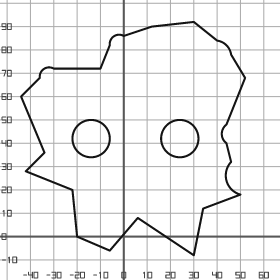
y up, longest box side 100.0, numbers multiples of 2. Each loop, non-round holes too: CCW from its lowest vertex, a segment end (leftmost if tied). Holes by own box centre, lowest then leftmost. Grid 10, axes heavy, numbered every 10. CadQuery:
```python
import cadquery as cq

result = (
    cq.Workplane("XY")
    .moveTo(30.0, -8.0)
    .lineTo(34.0, 12.0)
    .lineTo(50.0, 18.0)
    .threePointArc((44.0, 24.0), (46.0, 32.0))
    .lineTo(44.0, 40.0)
    .threePointArc((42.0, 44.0), (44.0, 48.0))
    .lineTo(52.0, 68.0)
    .lineTo(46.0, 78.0)
    .threePointArc((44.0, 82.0), (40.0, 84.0))
    .lineTo(30.0, 92.0)
    .lineTo(12.0, 90.0)
    .lineTo(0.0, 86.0)
    .threePointArc((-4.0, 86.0), (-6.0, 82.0))
    .lineTo(-10.0, 72.0)
    .lineTo(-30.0, 72.0)
    .threePointArc((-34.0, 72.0), (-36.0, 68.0))
    .lineTo(-44.0, 60.0)
    .lineTo(-34.0, 36.0)
    .lineTo(-42.0, 28.0)
    .lineTo(-22.0, 20.0)
    .lineTo(-20.0, 0.0)
    .lineTo(-6.0, -6.0)
    .lineTo(6.0, 8.0)
    .close()
    .moveTo(-14.0, 42.0)
    .circle(8.0)
    .moveTo(24.0, 42.0)
    .circle(8.0)
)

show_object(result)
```